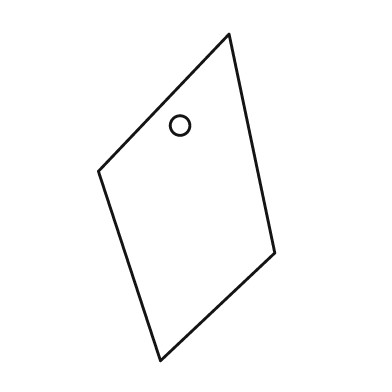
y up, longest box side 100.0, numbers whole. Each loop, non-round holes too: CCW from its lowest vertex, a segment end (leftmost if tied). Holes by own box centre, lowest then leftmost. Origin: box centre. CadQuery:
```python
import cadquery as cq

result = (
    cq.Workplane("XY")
    .moveTo(-8.0, -50.0)
    .lineTo(27.0, -17.0)
    .lineTo(13.0, 50.0)
    .lineTo(-27.0, 8.0)
    .close()
    .moveTo(-2.0, 22.0)
    .circle(3.0)
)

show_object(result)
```